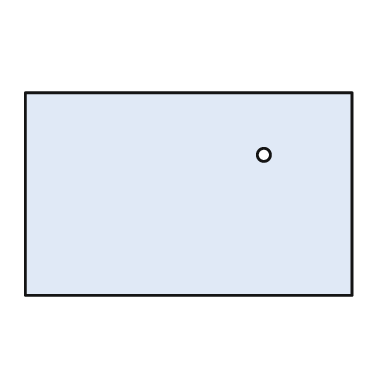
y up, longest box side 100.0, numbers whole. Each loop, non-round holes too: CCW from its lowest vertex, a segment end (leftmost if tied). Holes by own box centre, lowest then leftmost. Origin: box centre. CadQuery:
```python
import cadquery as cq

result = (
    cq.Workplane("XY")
    .moveTo(-50.0, -31.0)
    .lineTo(50.0, -31.0)
    .lineTo(50.0, 31.0)
    .lineTo(-50.0, 31.0)
    .close()
    .moveTo(23.0, 12.0)
    .circle(2.0)
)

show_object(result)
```